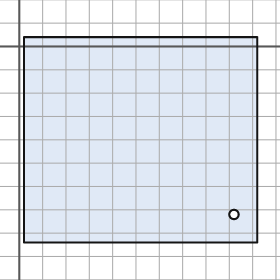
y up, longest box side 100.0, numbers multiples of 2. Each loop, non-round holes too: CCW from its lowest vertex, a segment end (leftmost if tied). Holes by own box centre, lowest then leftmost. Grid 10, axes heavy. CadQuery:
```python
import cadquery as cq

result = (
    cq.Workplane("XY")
    .moveTo(2.0, -84.0)
    .lineTo(102.0, -84.0)
    .lineTo(102.0, 4.0)
    .lineTo(2.0, 4.0)
    .close()
    .moveTo(92.0, -72.0)
    .circle(2.0)
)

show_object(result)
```